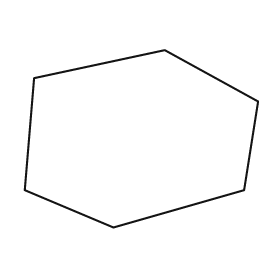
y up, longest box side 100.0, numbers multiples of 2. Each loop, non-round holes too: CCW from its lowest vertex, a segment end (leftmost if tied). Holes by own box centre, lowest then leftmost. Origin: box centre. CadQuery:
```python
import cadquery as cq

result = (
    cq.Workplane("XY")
    .moveTo(-12.0, -38.0)
    .lineTo(44.0, -22.0)
    .lineTo(50.0, 16.0)
    .lineTo(10.0, 38.0)
    .lineTo(-46.0, 26.0)
    .lineTo(-50.0, -22.0)
    .close()
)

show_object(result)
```